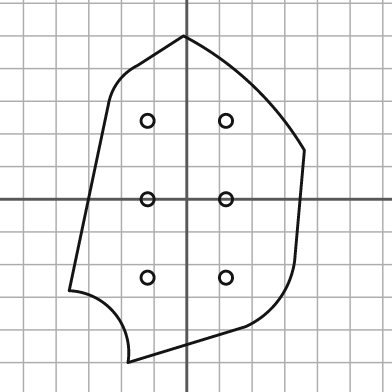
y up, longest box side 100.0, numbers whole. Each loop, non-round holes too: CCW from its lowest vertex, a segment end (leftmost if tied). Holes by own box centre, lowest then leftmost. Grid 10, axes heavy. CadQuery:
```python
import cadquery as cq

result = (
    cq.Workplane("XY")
    .moveTo(-18.0, -50.0)
    .lineTo(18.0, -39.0)
    .threePointArc((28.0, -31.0), (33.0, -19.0))
    .lineTo(36.0, 15.0)
    .threePointArc((20.0, 35.0), (-1.0, 50.0))
    .lineTo(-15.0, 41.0)
    .threePointArc((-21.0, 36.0), (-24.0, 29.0))
    .lineTo(-36.0, -28.0)
    .threePointArc((-22.0, -35.0), (-18.0, -50.0))
    .close()
    .moveTo(-12.0, -24.0)
    .circle(2.0)
    .moveTo(12.0, -24.0)
    .circle(2.0)
    .moveTo(-12.0, 0.0)
    .circle(2.0)
    .moveTo(12.0, 0.0)
    .circle(2.0)
    .moveTo(-12.0, 24.0)
    .circle(2.0)
    .moveTo(12.0, 24.0)
    .circle(2.0)
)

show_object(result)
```